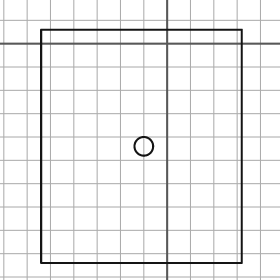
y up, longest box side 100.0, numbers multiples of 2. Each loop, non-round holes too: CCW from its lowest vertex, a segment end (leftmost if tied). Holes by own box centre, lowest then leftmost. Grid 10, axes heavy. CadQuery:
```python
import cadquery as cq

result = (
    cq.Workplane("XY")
    .moveTo(-54.0, -94.0)
    .lineTo(32.0, -94.0)
    .lineTo(32.0, 6.0)
    .lineTo(-54.0, 6.0)
    .close()
    .moveTo(-10.0, -44.0)
    .circle(4.0)
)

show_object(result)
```